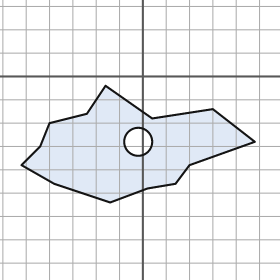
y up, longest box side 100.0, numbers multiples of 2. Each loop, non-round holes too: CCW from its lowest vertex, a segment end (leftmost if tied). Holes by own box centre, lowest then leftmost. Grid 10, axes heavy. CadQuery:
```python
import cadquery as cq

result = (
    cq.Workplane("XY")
    .moveTo(-14.0, -54.0)
    .lineTo(2.0, -48.0)
    .lineTo(14.0, -46.0)
    .lineTo(20.0, -38.0)
    .lineTo(48.0, -28.0)
    .lineTo(30.0, -14.0)
    .lineTo(4.0, -18.0)
    .lineTo(-16.0, -4.0)
    .lineTo(-24.0, -16.0)
    .lineTo(-40.0, -20.0)
    .lineTo(-44.0, -30.0)
    .lineTo(-52.0, -38.0)
    .lineTo(-38.0, -46.0)
    .close()
    .moveTo(-2.0, -28.0)
    .circle(6.0)
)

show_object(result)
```